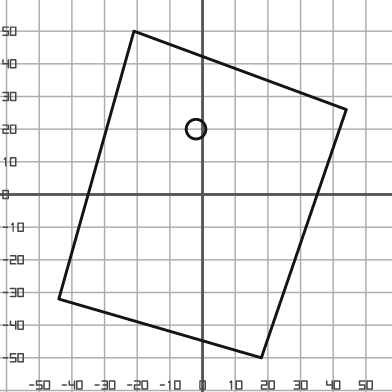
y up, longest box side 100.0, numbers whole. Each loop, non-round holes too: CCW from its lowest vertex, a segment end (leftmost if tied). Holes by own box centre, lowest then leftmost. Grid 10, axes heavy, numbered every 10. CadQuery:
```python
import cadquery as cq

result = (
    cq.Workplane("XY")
    .moveTo(18.0, -50.0)
    .lineTo(44.0, 26.0)
    .lineTo(-21.0, 50.0)
    .lineTo(-44.0, -32.0)
    .close()
    .moveTo(-2.0, 20.0)
    .circle(3.0)
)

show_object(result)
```